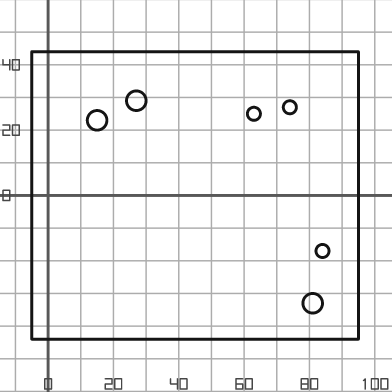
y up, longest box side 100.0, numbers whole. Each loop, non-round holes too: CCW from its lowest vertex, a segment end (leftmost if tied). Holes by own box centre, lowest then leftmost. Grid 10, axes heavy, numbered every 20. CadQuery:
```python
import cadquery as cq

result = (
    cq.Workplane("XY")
    .moveTo(-5.0, -44.0)
    .lineTo(95.0, -44.0)
    .lineTo(95.0, 44.0)
    .lineTo(-5.0, 44.0)
    .close()
    .moveTo(81.0, -33.0)
    .circle(3.0)
    .moveTo(84.0, -17.0)
    .circle(2.0)
    .moveTo(15.0, 23.0)
    .circle(3.0)
    .moveTo(63.0, 25.0)
    .circle(2.0)
    .moveTo(74.0, 27.0)
    .circle(2.0)
    .moveTo(27.0, 29.0)
    .circle(3.0)
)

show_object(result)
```